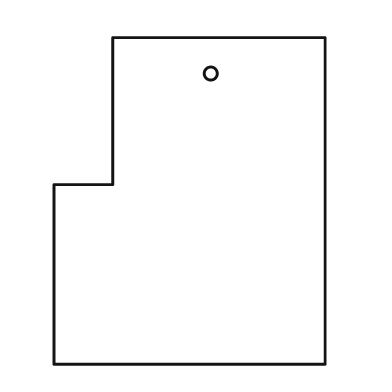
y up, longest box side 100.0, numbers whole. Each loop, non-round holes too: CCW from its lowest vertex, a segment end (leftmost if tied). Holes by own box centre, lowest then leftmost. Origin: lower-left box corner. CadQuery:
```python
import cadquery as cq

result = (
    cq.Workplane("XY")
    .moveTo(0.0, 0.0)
    .lineTo(83.0, 0.0)
    .lineTo(83.0, 100.0)
    .lineTo(18.0, 100.0)
    .lineTo(18.0, 55.0)
    .lineTo(0.0, 55.0)
    .close()
    .moveTo(48.0, 89.0)
    .circle(2.0)
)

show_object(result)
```